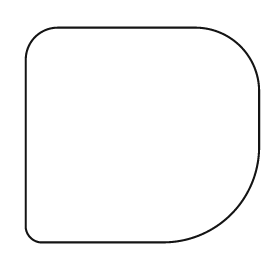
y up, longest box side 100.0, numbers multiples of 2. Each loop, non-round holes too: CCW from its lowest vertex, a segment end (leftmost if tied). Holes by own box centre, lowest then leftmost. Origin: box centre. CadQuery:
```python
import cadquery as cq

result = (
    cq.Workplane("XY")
    .moveTo(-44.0, -46.0)
    .lineTo(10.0, -46.0)
    .threePointArc((38.0, -34.0), (50.0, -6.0))
    .lineTo(50.0, 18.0)
    .threePointArc((42.0, 38.0), (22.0, 46.0))
    .lineTo(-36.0, 46.0)
    .threePointArc((-46.0, 42.0), (-50.0, 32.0))
    .lineTo(-50.0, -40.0)
    .threePointArc((-48.0, -44.0), (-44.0, -46.0))
    .close()
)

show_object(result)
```